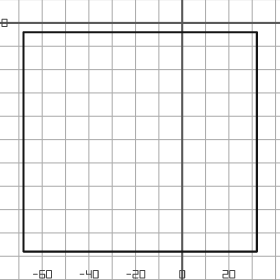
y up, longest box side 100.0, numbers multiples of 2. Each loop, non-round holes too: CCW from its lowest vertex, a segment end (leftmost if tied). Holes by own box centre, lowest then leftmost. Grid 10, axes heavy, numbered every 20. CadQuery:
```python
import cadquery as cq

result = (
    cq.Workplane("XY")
    .moveTo(-68.0, -98.0)
    .lineTo(32.0, -98.0)
    .lineTo(32.0, -4.0)
    .lineTo(-68.0, -4.0)
    .close()
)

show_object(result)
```